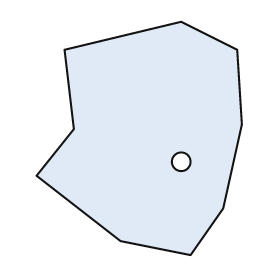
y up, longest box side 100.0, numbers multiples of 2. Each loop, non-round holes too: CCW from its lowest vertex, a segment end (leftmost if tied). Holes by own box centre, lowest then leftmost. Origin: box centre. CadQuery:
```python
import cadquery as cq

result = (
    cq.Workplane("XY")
    .moveTo(22.0, -50.0)
    .lineTo(36.0, -30.0)
    .lineTo(44.0, 6.0)
    .lineTo(42.0, 38.0)
    .lineTo(18.0, 50.0)
    .lineTo(-32.0, 38.0)
    .lineTo(-28.0, 4.0)
    .lineTo(-44.0, -16.0)
    .lineTo(-8.0, -44.0)
    .close()
    .moveTo(18.0, -10.0)
    .circle(4.0)
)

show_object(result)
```